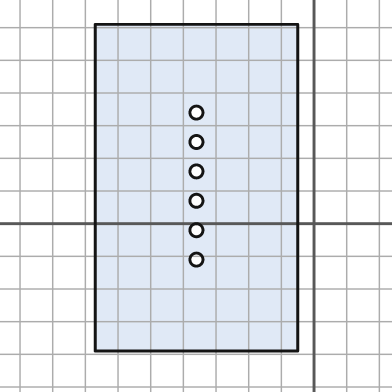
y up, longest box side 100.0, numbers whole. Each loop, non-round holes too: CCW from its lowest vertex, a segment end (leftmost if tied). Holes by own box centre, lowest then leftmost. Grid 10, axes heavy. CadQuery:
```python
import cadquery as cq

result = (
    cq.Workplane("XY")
    .moveTo(-67.0, -39.0)
    .lineTo(-5.0, -39.0)
    .lineTo(-5.0, 61.0)
    .lineTo(-67.0, 61.0)
    .close()
    .moveTo(-36.0, -11.0)
    .circle(2.0)
    .moveTo(-36.0, -2.0)
    .circle(2.0)
    .moveTo(-36.0, 7.0)
    .circle(2.0)
    .moveTo(-36.0, 16.0)
    .circle(2.0)
    .moveTo(-36.0, 25.0)
    .circle(2.0)
    .moveTo(-36.0, 34.0)
    .circle(2.0)
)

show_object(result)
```